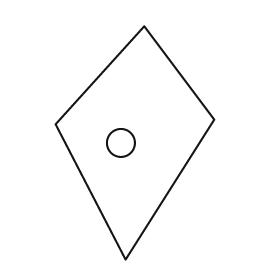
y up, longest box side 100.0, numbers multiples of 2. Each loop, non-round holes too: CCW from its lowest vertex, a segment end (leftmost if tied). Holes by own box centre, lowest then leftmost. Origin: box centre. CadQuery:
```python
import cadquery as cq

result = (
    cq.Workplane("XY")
    .moveTo(-4.0, -50.0)
    .lineTo(34.0, 10.0)
    .lineTo(4.0, 50.0)
    .lineTo(-34.0, 8.0)
    .close()
    .moveTo(-6.0, 0.0)
    .circle(6.0)
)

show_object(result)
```